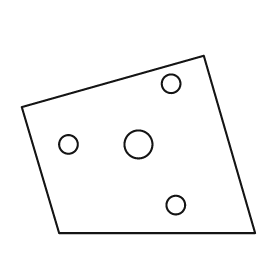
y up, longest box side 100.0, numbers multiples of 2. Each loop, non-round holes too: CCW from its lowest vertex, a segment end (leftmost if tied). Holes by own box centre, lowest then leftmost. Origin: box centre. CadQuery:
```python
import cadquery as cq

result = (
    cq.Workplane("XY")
    .moveTo(-34.0, -38.0)
    .lineTo(50.0, -38.0)
    .lineTo(28.0, 38.0)
    .lineTo(-50.0, 16.0)
    .close()
    .moveTo(16.0, -26.0)
    .circle(4.0)
    .moveTo(-30.0, 0.0)
    .circle(4.0)
    .moveTo(0.0, 0.0)
    .circle(6.0)
    .moveTo(14.0, 26.0)
    .circle(4.0)
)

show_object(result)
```